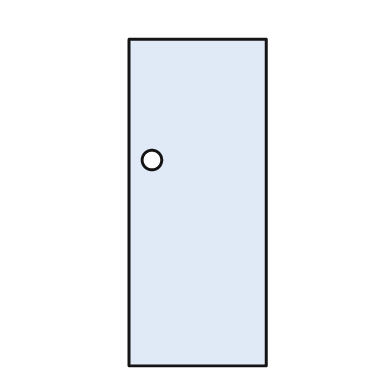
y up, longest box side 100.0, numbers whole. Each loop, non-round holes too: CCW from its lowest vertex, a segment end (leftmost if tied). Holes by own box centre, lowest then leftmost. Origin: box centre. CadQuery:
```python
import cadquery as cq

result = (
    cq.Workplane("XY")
    .moveTo(-21.0, -50.0)
    .lineTo(21.0, -50.0)
    .lineTo(21.0, 50.0)
    .lineTo(-21.0, 50.0)
    .close()
    .moveTo(-14.0, 13.0)
    .circle(3.0)
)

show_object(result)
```